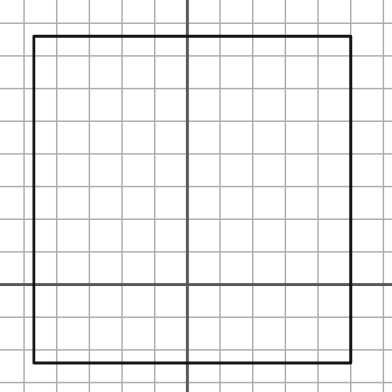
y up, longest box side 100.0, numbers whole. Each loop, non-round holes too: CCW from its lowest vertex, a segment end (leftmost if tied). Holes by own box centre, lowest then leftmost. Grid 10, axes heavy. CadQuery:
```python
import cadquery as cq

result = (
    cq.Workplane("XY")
    .moveTo(-47.0, -24.0)
    .lineTo(50.0, -24.0)
    .lineTo(50.0, 76.0)
    .lineTo(-47.0, 76.0)
    .close()
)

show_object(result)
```